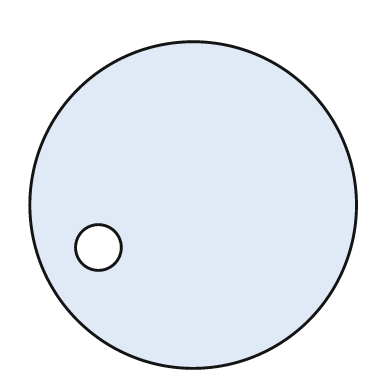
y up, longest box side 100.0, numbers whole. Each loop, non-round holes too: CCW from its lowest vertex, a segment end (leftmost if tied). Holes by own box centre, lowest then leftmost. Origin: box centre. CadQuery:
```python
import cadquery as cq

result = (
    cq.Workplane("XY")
    .moveTo(0.0, 0.0)
    .circle(50.0)
    .moveTo(-29.0, -13.0)
    .circle(7.0)
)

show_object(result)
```